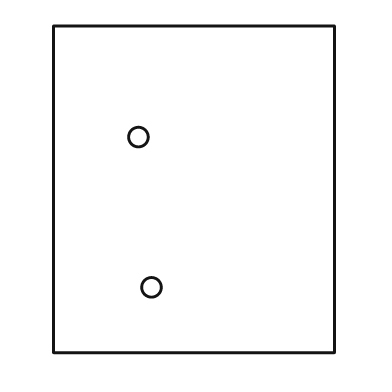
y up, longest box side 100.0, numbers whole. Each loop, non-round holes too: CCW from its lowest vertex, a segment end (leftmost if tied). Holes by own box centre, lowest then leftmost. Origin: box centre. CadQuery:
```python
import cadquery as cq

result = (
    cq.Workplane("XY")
    .moveTo(-43.0, -50.0)
    .lineTo(43.0, -50.0)
    .lineTo(43.0, 50.0)
    .lineTo(-43.0, 50.0)
    .close()
    .moveTo(-13.0, -30.0)
    .circle(3.0)
    .moveTo(-17.0, 16.0)
    .circle(3.0)
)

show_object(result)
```